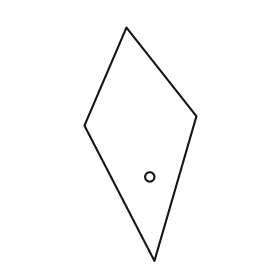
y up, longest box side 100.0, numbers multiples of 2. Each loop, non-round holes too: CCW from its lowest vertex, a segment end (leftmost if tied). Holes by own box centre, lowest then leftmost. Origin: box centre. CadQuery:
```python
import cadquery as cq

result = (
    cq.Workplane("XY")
    .moveTo(6.0, -50.0)
    .lineTo(24.0, 12.0)
    .lineTo(-6.0, 50.0)
    .lineTo(-24.0, 8.0)
    .close()
    .moveTo(4.0, -14.0)
    .circle(2.0)
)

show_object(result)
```